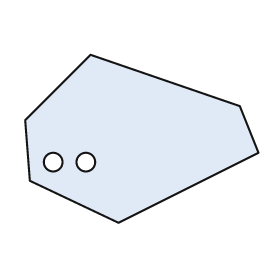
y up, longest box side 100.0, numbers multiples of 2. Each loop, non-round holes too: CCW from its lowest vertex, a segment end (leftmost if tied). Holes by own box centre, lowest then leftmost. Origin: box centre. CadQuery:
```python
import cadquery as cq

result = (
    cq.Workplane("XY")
    .moveTo(-10.0, -36.0)
    .lineTo(50.0, -6.0)
    .lineTo(42.0, 14.0)
    .lineTo(-22.0, 36.0)
    .lineTo(-50.0, 8.0)
    .lineTo(-48.0, -18.0)
    .close()
    .moveTo(-38.0, -10.0)
    .circle(4.0)
    .moveTo(-24.0, -10.0)
    .circle(4.0)
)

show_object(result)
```